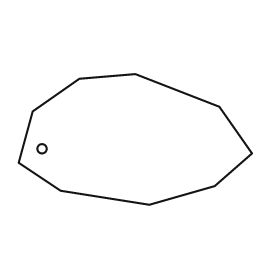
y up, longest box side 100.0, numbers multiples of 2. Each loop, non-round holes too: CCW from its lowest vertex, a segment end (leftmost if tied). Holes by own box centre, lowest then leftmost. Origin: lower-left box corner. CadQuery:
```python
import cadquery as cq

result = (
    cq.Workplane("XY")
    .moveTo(56.0, 0.0)
    .lineTo(84.0, 8.0)
    .lineTo(100.0, 22.0)
    .lineTo(86.0, 42.0)
    .lineTo(50.0, 56.0)
    .lineTo(26.0, 54.0)
    .lineTo(6.0, 40.0)
    .lineTo(0.0, 18.0)
    .lineTo(18.0, 6.0)
    .close()
    .moveTo(10.0, 24.0)
    .circle(2.0)
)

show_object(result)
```